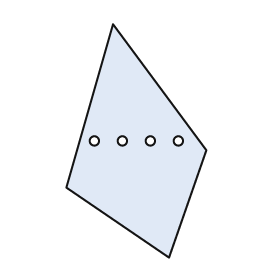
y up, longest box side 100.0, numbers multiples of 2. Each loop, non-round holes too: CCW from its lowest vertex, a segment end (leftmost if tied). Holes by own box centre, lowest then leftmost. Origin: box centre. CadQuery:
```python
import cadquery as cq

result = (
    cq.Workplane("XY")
    .moveTo(14.0, -50.0)
    .lineTo(30.0, -4.0)
    .lineTo(-10.0, 50.0)
    .lineTo(-30.0, -20.0)
    .close()
    .moveTo(-18.0, 0.0)
    .circle(2.0)
    .moveTo(-6.0, 0.0)
    .circle(2.0)
    .moveTo(6.0, 0.0)
    .circle(2.0)
    .moveTo(18.0, 0.0)
    .circle(2.0)
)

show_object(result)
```